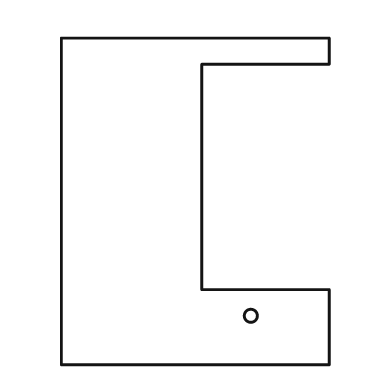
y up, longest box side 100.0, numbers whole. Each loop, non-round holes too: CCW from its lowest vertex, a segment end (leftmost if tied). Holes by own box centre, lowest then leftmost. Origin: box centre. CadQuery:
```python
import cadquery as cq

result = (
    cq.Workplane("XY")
    .moveTo(-41.0, -50.0)
    .lineTo(41.0, -50.0)
    .lineTo(41.0, -27.0)
    .lineTo(2.0, -27.0)
    .lineTo(2.0, 42.0)
    .lineTo(41.0, 42.0)
    .lineTo(41.0, 50.0)
    .lineTo(-41.0, 50.0)
    .close()
    .moveTo(17.0, -35.0)
    .circle(2.0)
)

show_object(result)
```